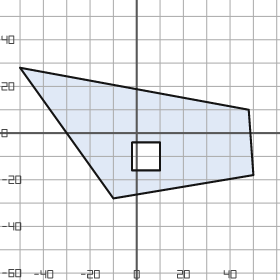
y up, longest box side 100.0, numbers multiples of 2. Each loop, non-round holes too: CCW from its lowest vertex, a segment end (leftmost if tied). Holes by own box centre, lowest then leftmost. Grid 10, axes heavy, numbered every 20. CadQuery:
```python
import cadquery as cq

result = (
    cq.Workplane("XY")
    .moveTo(-10.0, -28.0)
    .lineTo(50.0, -18.0)
    .lineTo(48.0, 10.0)
    .lineTo(-50.0, 28.0)
    .close()
    .moveTo(-2.0, -16.0)
    .lineTo(10.0, -16.0)
    .lineTo(10.0, -4.0)
    .lineTo(-2.0, -4.0)
    .close()
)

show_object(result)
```